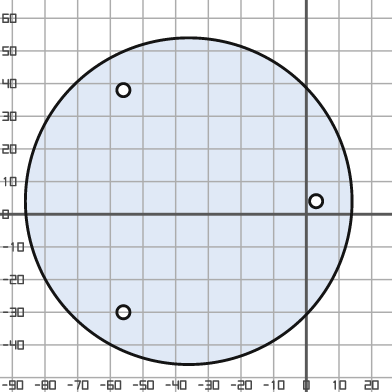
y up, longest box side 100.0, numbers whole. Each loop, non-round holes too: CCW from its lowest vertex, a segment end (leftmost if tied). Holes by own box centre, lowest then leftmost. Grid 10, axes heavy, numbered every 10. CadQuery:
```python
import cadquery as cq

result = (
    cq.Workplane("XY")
    .moveTo(-36.0, 4.0)
    .circle(50.0)
    .moveTo(-56.0, -30.0)
    .circle(2.0)
    .moveTo(3.0, 4.0)
    .circle(2.0)
    .moveTo(-56.0, 38.0)
    .circle(2.0)
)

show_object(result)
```